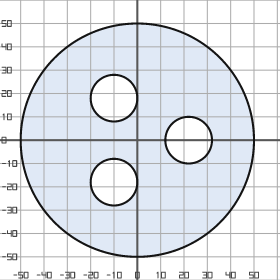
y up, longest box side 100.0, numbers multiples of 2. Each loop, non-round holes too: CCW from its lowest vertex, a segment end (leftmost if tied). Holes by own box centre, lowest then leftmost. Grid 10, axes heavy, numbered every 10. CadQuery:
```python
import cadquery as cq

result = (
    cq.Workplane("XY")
    .moveTo(0.0, 0.0)
    .circle(50.0)
    .moveTo(-10.0, -18.0)
    .circle(10.0)
    .moveTo(22.0, 0.0)
    .circle(10.0)
    .moveTo(-10.0, 18.0)
    .circle(10.0)
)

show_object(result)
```